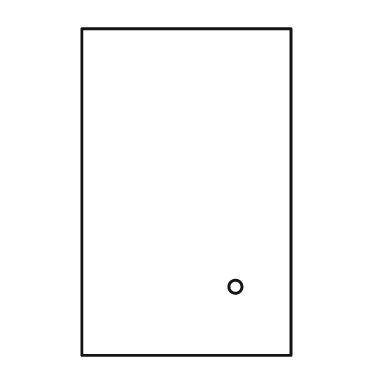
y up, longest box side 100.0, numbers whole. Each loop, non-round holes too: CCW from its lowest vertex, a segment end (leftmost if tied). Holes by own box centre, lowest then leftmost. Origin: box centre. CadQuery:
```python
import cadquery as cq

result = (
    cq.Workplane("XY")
    .moveTo(-32.0, -50.0)
    .lineTo(32.0, -50.0)
    .lineTo(32.0, 50.0)
    .lineTo(-32.0, 50.0)
    .close()
    .moveTo(15.0, -29.0)
    .circle(2.0)
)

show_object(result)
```